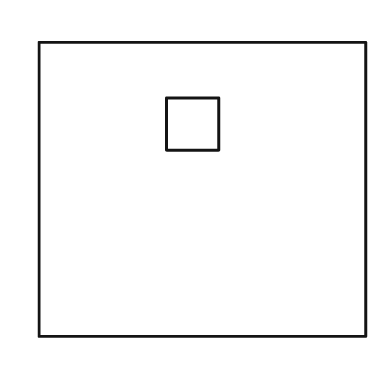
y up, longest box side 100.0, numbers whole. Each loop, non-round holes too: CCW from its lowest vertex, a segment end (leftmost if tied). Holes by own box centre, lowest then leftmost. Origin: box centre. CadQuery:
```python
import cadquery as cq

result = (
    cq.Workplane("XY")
    .moveTo(-50.0, -45.0)
    .lineTo(50.0, -45.0)
    .lineTo(50.0, 45.0)
    .lineTo(-50.0, 45.0)
    .close()
    .moveTo(-11.0, 12.0)
    .lineTo(5.0, 12.0)
    .lineTo(5.0, 28.0)
    .lineTo(-11.0, 28.0)
    .close()
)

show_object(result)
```